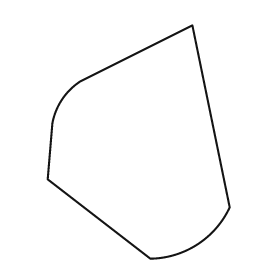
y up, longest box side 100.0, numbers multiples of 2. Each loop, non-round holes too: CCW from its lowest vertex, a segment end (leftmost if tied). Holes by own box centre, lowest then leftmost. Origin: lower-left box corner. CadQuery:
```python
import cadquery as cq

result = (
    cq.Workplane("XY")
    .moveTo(44.0, 0.0)
    .threePointArc((64.0, 6.0), (78.0, 22.0))
    .lineTo(62.0, 100.0)
    .lineTo(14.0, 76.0)
    .threePointArc((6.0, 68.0), (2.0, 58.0))
    .lineTo(0.0, 34.0)
    .close()
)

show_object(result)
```